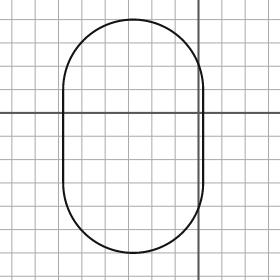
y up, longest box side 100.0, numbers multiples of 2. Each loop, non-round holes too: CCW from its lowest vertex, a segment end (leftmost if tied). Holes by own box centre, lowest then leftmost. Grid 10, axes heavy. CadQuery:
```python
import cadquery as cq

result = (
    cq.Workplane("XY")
    .moveTo(-58.0, -30.0)
    .threePointArc((-28.0, -60.0), (2.0, -30.0))
    .lineTo(2.0, 10.0)
    .threePointArc((-28.0, 40.0), (-58.0, 10.0))
    .close()
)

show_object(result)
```